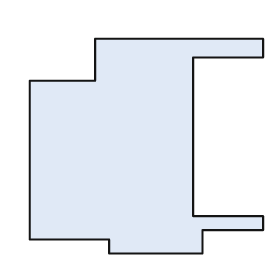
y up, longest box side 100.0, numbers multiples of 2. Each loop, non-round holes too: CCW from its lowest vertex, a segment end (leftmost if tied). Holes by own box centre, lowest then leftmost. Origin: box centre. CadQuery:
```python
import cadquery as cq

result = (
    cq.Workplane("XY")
    .moveTo(-16.0, -46.0)
    .lineTo(24.0, -46.0)
    .lineTo(24.0, -36.0)
    .lineTo(50.0, -36.0)
    .lineTo(50.0, -30.0)
    .lineTo(20.0, -30.0)
    .lineTo(20.0, 38.0)
    .lineTo(50.0, 38.0)
    .lineTo(50.0, 46.0)
    .lineTo(-22.0, 46.0)
    .lineTo(-22.0, 28.0)
    .lineTo(-50.0, 28.0)
    .lineTo(-50.0, -40.0)
    .lineTo(-16.0, -40.0)
    .close()
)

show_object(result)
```